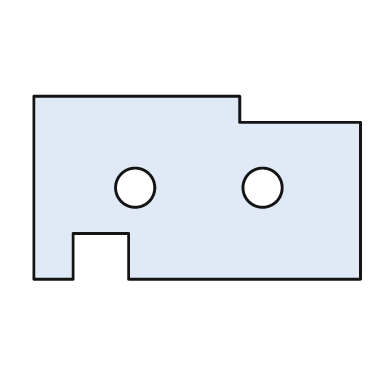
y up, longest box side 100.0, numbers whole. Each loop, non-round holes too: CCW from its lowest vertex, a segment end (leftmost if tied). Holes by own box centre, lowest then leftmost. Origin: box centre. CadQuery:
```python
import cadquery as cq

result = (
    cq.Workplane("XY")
    .moveTo(-50.0, -28.0)
    .lineTo(-38.0, -28.0)
    .lineTo(-38.0, -14.0)
    .lineTo(-21.0, -14.0)
    .lineTo(-21.0, -28.0)
    .lineTo(50.0, -28.0)
    .lineTo(50.0, 20.0)
    .lineTo(13.0, 20.0)
    .lineTo(13.0, 28.0)
    .lineTo(-50.0, 28.0)
    .close()
    .moveTo(-19.0, 0.0)
    .circle(6.0)
    .moveTo(20.0, 0.0)
    .circle(6.0)
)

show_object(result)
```